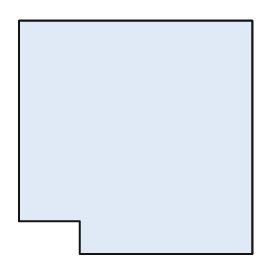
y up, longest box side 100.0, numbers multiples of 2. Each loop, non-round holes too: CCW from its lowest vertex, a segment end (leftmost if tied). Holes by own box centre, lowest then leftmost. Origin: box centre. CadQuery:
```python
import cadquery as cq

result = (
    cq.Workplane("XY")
    .moveTo(-24.0, -50.0)
    .lineTo(50.0, -50.0)
    .lineTo(50.0, 50.0)
    .lineTo(-50.0, 50.0)
    .lineTo(-50.0, -36.0)
    .lineTo(-24.0, -36.0)
    .close()
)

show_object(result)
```